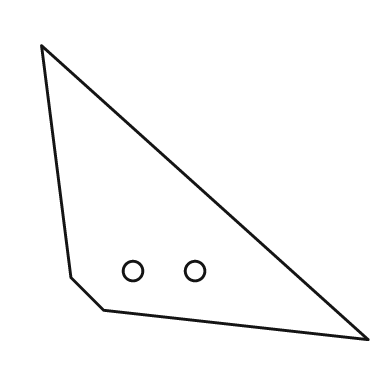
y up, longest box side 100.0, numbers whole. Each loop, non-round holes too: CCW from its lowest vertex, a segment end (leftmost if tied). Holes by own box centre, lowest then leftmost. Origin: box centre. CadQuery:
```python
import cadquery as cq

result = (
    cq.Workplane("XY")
    .moveTo(50.0, -45.0)
    .lineTo(-50.0, 45.0)
    .lineTo(-41.0, -26.0)
    .lineTo(-31.0, -36.0)
    .close()
    .moveTo(-22.0, -24.0)
    .circle(3.0)
    .moveTo(-3.0, -24.0)
    .circle(3.0)
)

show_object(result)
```